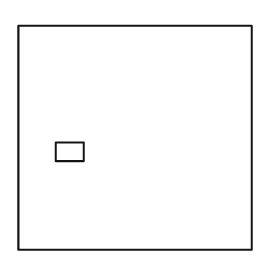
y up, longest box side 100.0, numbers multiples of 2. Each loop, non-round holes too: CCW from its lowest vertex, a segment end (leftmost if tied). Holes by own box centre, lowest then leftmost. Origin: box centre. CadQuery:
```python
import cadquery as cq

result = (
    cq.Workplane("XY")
    .moveTo(-50.0, -48.0)
    .lineTo(50.0, -48.0)
    .lineTo(50.0, 48.0)
    .lineTo(-50.0, 48.0)
    .close()
    .moveTo(-34.0, -10.0)
    .lineTo(-22.0, -10.0)
    .lineTo(-22.0, -2.0)
    .lineTo(-34.0, -2.0)
    .close()
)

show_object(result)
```